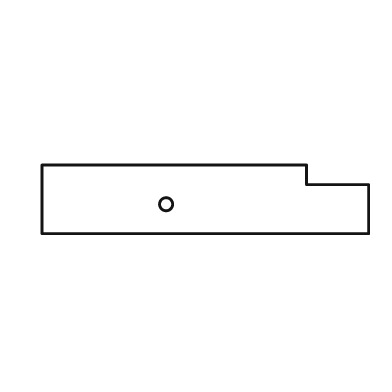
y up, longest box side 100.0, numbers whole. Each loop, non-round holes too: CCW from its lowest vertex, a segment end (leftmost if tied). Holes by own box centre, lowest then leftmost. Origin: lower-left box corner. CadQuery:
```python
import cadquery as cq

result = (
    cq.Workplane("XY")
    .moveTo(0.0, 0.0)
    .lineTo(100.0, 0.0)
    .lineTo(100.0, 15.0)
    .lineTo(81.0, 15.0)
    .lineTo(81.0, 21.0)
    .lineTo(0.0, 21.0)
    .close()
    .moveTo(38.0, 9.0)
    .circle(2.0)
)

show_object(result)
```